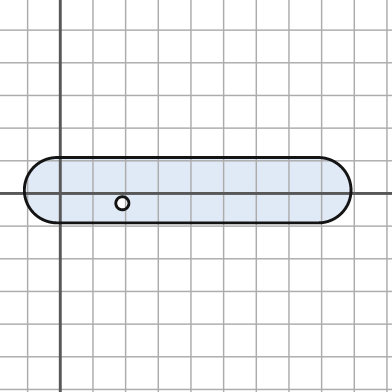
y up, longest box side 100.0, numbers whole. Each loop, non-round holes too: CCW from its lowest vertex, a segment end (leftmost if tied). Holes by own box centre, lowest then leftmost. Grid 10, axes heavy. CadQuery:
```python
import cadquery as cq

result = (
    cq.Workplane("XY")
    .moveTo(-1.0, -9.0)
    .lineTo(79.0, -9.0)
    .threePointArc((89.0, 1.0), (79.0, 11.0))
    .lineTo(-1.0, 11.0)
    .threePointArc((-11.0, 1.0), (-1.0, -9.0))
    .close()
    .moveTo(19.0, -3.0)
    .circle(2.0)
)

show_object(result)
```